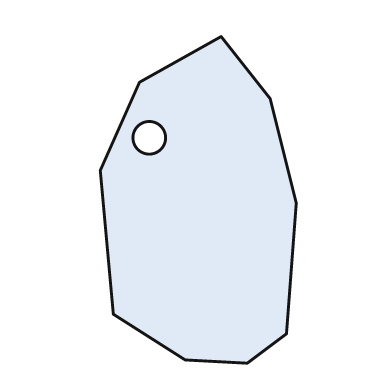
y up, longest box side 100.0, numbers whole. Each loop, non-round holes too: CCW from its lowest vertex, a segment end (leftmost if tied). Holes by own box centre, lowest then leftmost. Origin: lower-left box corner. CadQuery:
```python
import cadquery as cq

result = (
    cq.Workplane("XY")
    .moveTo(45.0, 0.0)
    .lineTo(57.0, 9.0)
    .lineTo(60.0, 49.0)
    .lineTo(52.0, 81.0)
    .lineTo(37.0, 100.0)
    .lineTo(12.0, 86.0)
    .lineTo(0.0, 59.0)
    .lineTo(4.0, 15.0)
    .lineTo(26.0, 1.0)
    .close()
    .moveTo(15.0, 69.0)
    .circle(5.0)
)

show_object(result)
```